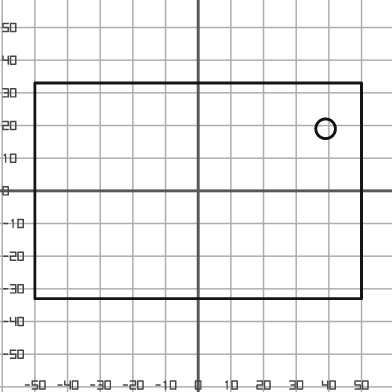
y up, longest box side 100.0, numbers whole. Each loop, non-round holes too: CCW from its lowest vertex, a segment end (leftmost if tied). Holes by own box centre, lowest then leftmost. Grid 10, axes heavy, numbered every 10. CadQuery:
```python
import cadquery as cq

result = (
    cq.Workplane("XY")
    .moveTo(-50.0, -33.0)
    .lineTo(50.0, -33.0)
    .lineTo(50.0, 33.0)
    .lineTo(-50.0, 33.0)
    .close()
    .moveTo(39.0, 19.0)
    .circle(3.0)
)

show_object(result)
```